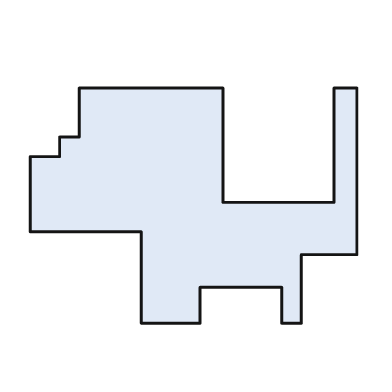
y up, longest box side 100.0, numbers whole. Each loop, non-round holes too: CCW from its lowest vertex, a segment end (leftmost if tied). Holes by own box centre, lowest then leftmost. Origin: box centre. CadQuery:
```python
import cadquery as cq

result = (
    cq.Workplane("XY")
    .moveTo(-16.0, -36.0)
    .lineTo(2.0, -36.0)
    .lineTo(2.0, -25.0)
    .lineTo(27.0, -25.0)
    .lineTo(27.0, -36.0)
    .lineTo(33.0, -36.0)
    .lineTo(33.0, -15.0)
    .lineTo(50.0, -15.0)
    .lineTo(50.0, 36.0)
    .lineTo(43.0, 36.0)
    .lineTo(43.0, 1.0)
    .lineTo(9.0, 1.0)
    .lineTo(9.0, 36.0)
    .lineTo(-35.0, 36.0)
    .lineTo(-35.0, 21.0)
    .lineTo(-41.0, 21.0)
    .lineTo(-41.0, 15.0)
    .lineTo(-50.0, 15.0)
    .lineTo(-50.0, -8.0)
    .lineTo(-16.0, -8.0)
    .close()
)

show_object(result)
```